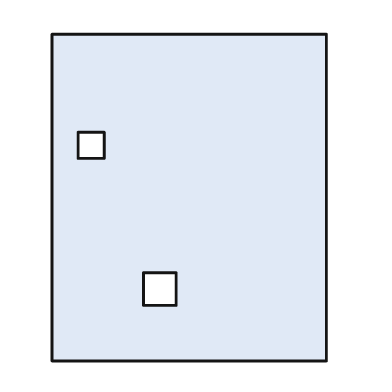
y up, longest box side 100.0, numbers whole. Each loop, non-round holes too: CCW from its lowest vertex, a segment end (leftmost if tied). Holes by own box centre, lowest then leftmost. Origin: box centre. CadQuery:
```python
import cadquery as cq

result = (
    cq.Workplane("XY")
    .moveTo(-42.0, -50.0)
    .lineTo(42.0, -50.0)
    .lineTo(42.0, 50.0)
    .lineTo(-42.0, 50.0)
    .close()
    .moveTo(-14.0, -33.0)
    .lineTo(-4.0, -33.0)
    .lineTo(-4.0, -23.0)
    .lineTo(-14.0, -23.0)
    .close()
    .moveTo(-34.0, 12.0)
    .lineTo(-26.0, 12.0)
    .lineTo(-26.0, 20.0)
    .lineTo(-34.0, 20.0)
    .close()
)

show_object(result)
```